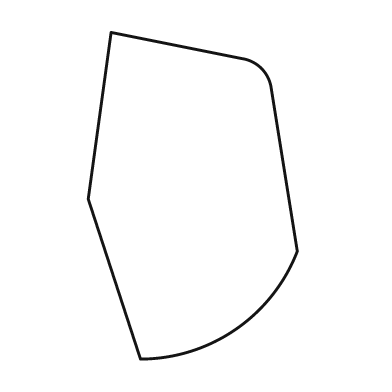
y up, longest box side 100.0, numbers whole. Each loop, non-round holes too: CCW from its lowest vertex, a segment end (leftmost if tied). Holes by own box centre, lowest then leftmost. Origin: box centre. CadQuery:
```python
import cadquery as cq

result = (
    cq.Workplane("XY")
    .moveTo(-16.0, -50.0)
    .threePointArc((13.0, -41.0), (32.0, -17.0))
    .lineTo(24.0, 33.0)
    .threePointArc((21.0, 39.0), (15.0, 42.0))
    .lineTo(-25.0, 50.0)
    .lineTo(-32.0, -1.0)
    .close()
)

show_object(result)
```